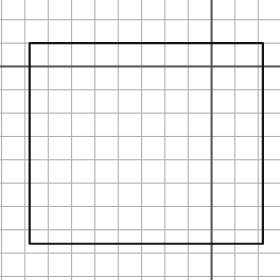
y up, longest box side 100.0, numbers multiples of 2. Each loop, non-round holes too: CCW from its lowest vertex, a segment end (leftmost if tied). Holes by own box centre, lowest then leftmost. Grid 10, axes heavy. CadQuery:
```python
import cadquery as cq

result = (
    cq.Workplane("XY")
    .moveTo(-78.0, -76.0)
    .lineTo(22.0, -76.0)
    .lineTo(22.0, 10.0)
    .lineTo(-78.0, 10.0)
    .close()
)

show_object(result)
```